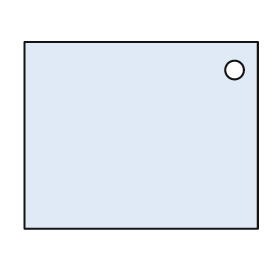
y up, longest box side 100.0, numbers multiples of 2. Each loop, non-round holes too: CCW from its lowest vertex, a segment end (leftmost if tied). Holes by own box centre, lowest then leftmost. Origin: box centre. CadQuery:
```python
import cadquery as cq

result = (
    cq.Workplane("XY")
    .moveTo(-50.0, -40.0)
    .lineTo(50.0, -40.0)
    .lineTo(50.0, 40.0)
    .lineTo(-50.0, 40.0)
    .close()
    .moveTo(40.0, 28.0)
    .circle(4.0)
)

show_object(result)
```